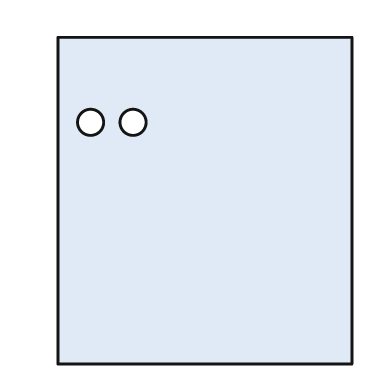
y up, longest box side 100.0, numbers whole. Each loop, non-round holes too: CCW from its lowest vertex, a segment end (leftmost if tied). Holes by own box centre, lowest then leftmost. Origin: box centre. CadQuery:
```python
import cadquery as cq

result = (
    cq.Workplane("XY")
    .moveTo(-45.0, -50.0)
    .lineTo(45.0, -50.0)
    .lineTo(45.0, 50.0)
    .lineTo(-45.0, 50.0)
    .close()
    .moveTo(-35.0, 24.0)
    .circle(4.0)
    .moveTo(-22.0, 24.0)
    .circle(4.0)
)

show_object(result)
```